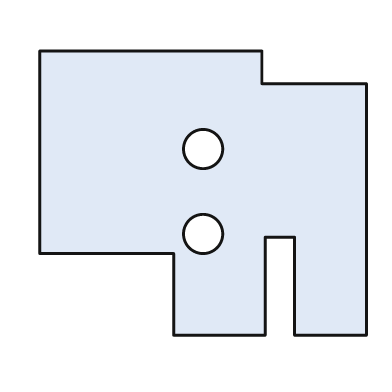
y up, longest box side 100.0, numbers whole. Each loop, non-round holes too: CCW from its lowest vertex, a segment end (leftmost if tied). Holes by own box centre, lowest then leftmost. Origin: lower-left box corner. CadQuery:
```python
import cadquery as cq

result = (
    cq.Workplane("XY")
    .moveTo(41.0, 0.0)
    .lineTo(69.0, 0.0)
    .lineTo(69.0, 30.0)
    .lineTo(78.0, 30.0)
    .lineTo(78.0, 0.0)
    .lineTo(100.0, 0.0)
    .lineTo(100.0, 77.0)
    .lineTo(68.0, 77.0)
    .lineTo(68.0, 87.0)
    .lineTo(0.0, 87.0)
    .lineTo(0.0, 25.0)
    .lineTo(41.0, 25.0)
    .close()
    .moveTo(50.0, 31.0)
    .circle(6.0)
    .moveTo(50.0, 57.0)
    .circle(6.0)
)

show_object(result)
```